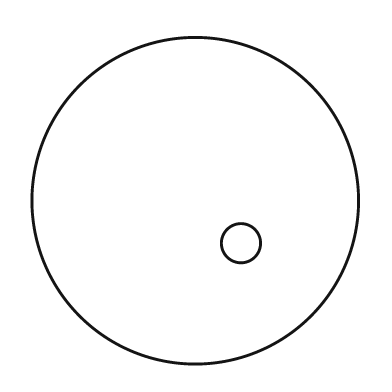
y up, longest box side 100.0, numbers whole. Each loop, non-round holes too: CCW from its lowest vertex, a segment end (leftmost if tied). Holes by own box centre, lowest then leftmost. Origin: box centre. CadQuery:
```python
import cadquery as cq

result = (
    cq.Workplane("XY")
    .moveTo(0.0, 0.0)
    .circle(50.0)
    .moveTo(14.0, -13.0)
    .circle(6.0)
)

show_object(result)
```